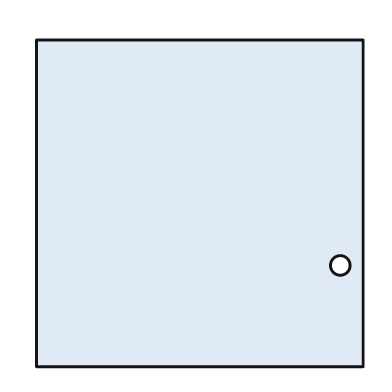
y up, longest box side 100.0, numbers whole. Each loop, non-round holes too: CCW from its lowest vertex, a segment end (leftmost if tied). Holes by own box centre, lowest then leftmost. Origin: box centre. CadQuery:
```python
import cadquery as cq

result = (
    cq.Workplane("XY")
    .moveTo(-50.0, -50.0)
    .lineTo(50.0, -50.0)
    .lineTo(50.0, 50.0)
    .lineTo(-50.0, 50.0)
    .close()
    .moveTo(43.0, -19.0)
    .circle(3.0)
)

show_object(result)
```